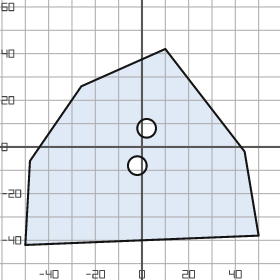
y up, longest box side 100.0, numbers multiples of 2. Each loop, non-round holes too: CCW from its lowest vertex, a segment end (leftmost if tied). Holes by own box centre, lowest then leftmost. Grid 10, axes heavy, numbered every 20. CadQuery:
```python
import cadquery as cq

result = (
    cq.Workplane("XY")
    .moveTo(-50.0, -42.0)
    .lineTo(50.0, -38.0)
    .lineTo(44.0, -2.0)
    .lineTo(10.0, 42.0)
    .lineTo(-26.0, 26.0)
    .lineTo(-48.0, -6.0)
    .close()
    .moveTo(-2.0, -8.0)
    .circle(4.0)
    .moveTo(2.0, 8.0)
    .circle(4.0)
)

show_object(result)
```